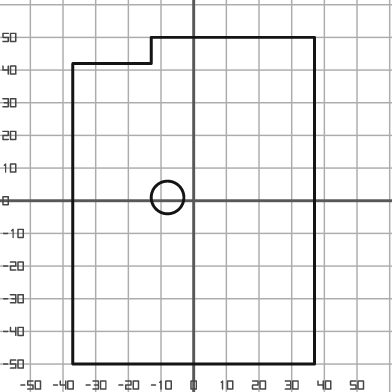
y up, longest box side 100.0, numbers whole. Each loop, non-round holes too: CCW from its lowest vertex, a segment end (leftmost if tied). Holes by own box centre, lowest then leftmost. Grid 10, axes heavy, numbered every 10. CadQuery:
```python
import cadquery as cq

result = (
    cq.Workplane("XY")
    .moveTo(-37.0, -50.0)
    .lineTo(37.0, -50.0)
    .lineTo(37.0, 50.0)
    .lineTo(-13.0, 50.0)
    .lineTo(-13.0, 42.0)
    .lineTo(-37.0, 42.0)
    .close()
    .moveTo(-8.0, 1.0)
    .circle(5.0)
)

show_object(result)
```